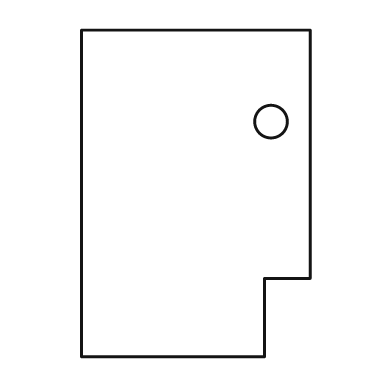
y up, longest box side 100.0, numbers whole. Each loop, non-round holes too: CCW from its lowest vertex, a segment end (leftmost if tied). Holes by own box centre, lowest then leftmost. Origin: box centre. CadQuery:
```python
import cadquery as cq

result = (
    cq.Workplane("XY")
    .moveTo(-35.0, -50.0)
    .lineTo(21.0, -50.0)
    .lineTo(21.0, -26.0)
    .lineTo(35.0, -26.0)
    .lineTo(35.0, 50.0)
    .lineTo(-35.0, 50.0)
    .close()
    .moveTo(23.0, 22.0)
    .circle(5.0)
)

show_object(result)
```